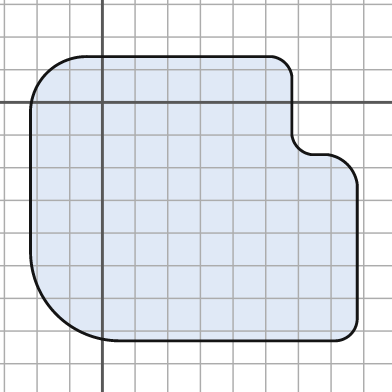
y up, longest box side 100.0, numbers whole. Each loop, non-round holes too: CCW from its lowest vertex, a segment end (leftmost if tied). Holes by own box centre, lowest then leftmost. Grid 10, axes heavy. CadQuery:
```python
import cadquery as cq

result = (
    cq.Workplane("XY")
    .moveTo(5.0, -73.0)
    .lineTo(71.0, -73.0)
    .threePointArc((76.0, -71.0), (78.0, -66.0))
    .lineTo(78.0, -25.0)
    .threePointArc((75.0, -19.0), (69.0, -16.0))
    .lineTo(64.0, -16.0)
    .threePointArc((60.0, -14.0), (58.0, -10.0))
    .lineTo(58.0, 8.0)
    .threePointArc((56.0, 12.0), (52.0, 14.0))
    .lineTo(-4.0, 14.0)
    .threePointArc((-17.0, 9.0), (-22.0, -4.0))
    .lineTo(-22.0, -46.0)
    .threePointArc((-14.0, -65.0), (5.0, -73.0))
    .close()
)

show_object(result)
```